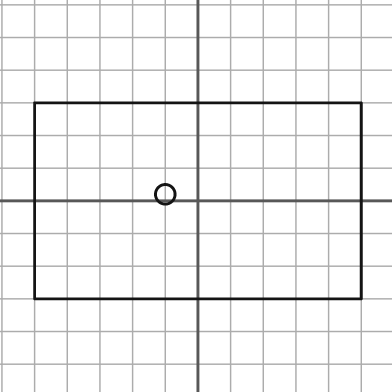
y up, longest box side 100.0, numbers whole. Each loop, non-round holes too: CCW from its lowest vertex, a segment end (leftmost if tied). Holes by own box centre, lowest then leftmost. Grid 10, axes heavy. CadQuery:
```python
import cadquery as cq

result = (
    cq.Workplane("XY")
    .moveTo(-50.0, -30.0)
    .lineTo(50.0, -30.0)
    .lineTo(50.0, 30.0)
    .lineTo(-50.0, 30.0)
    .close()
    .moveTo(-10.0, 2.0)
    .circle(3.0)
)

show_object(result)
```